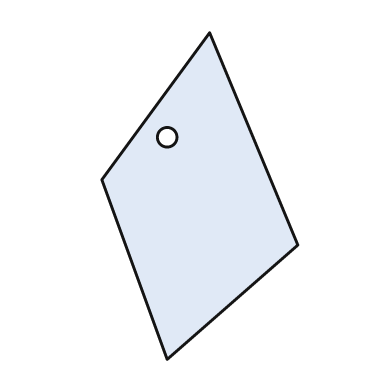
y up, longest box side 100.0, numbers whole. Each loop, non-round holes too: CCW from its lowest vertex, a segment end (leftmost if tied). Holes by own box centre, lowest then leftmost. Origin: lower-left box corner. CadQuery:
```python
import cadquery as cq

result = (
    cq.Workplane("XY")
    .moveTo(20.0, 0.0)
    .lineTo(60.0, 35.0)
    .lineTo(33.0, 100.0)
    .lineTo(0.0, 55.0)
    .close()
    .moveTo(20.0, 68.0)
    .circle(3.0)
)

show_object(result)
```